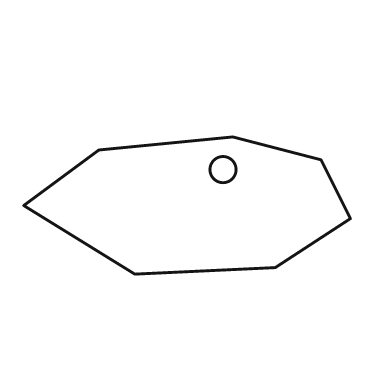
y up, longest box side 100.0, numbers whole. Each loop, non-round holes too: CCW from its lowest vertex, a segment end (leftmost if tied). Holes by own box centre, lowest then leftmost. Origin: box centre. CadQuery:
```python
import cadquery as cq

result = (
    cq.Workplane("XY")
    .moveTo(-16.0, -21.0)
    .lineTo(27.0, -19.0)
    .lineTo(50.0, -4.0)
    .lineTo(41.0, 14.0)
    .lineTo(14.0, 21.0)
    .lineTo(-27.0, 17.0)
    .lineTo(-50.0, 0.0)
    .close()
    .moveTo(11.0, 11.0)
    .circle(4.0)
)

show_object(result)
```